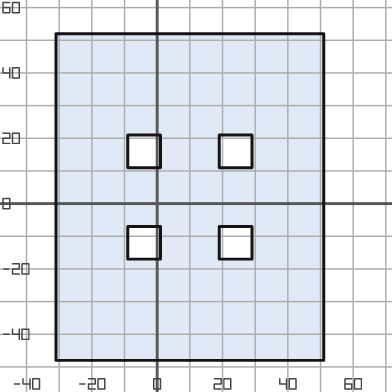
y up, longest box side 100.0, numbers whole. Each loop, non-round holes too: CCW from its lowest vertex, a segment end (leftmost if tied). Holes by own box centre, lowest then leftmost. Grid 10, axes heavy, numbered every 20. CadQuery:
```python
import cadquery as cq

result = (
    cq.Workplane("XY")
    .moveTo(-31.0, -48.0)
    .lineTo(51.0, -48.0)
    .lineTo(51.0, 52.0)
    .lineTo(-31.0, 52.0)
    .close()
    .moveTo(-9.0, -17.0)
    .lineTo(1.0, -17.0)
    .lineTo(1.0, -7.0)
    .lineTo(-9.0, -7.0)
    .close()
    .moveTo(19.0, -17.0)
    .lineTo(29.0, -17.0)
    .lineTo(29.0, -7.0)
    .lineTo(19.0, -7.0)
    .close()
    .moveTo(-9.0, 11.0)
    .lineTo(1.0, 11.0)
    .lineTo(1.0, 21.0)
    .lineTo(-9.0, 21.0)
    .close()
    .moveTo(19.0, 11.0)
    .lineTo(29.0, 11.0)
    .lineTo(29.0, 21.0)
    .lineTo(19.0, 21.0)
    .close()
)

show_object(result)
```